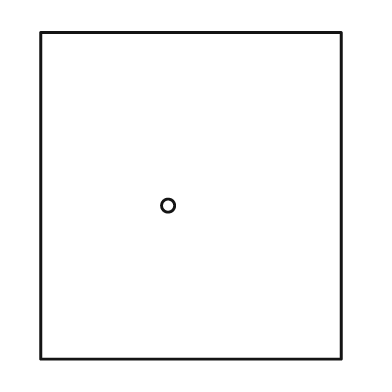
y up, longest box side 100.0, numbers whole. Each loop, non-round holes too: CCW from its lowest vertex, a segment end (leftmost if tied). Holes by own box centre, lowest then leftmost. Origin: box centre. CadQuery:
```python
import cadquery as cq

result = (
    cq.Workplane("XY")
    .moveTo(-46.0, -50.0)
    .lineTo(46.0, -50.0)
    .lineTo(46.0, 50.0)
    .lineTo(-46.0, 50.0)
    .close()
    .moveTo(-7.0, -3.0)
    .circle(2.0)
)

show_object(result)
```